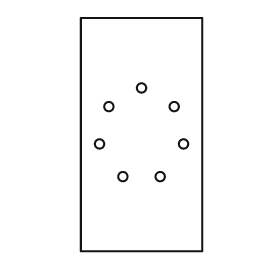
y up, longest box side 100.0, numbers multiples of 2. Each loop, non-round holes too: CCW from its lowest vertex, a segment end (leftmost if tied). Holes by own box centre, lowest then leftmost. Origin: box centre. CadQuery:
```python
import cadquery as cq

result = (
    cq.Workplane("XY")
    .moveTo(-26.0, -50.0)
    .lineTo(26.0, -50.0)
    .lineTo(26.0, 50.0)
    .lineTo(-26.0, 50.0)
    .close()
    .moveTo(-8.0, -18.0)
    .circle(2.0)
    .moveTo(8.0, -18.0)
    .circle(2.0)
    .moveTo(-18.0, -4.0)
    .circle(2.0)
    .moveTo(18.0, -4.0)
    .circle(2.0)
    .moveTo(-14.0, 12.0)
    .circle(2.0)
    .moveTo(14.0, 12.0)
    .circle(2.0)
    .moveTo(0.0, 20.0)
    .circle(2.0)
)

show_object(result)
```